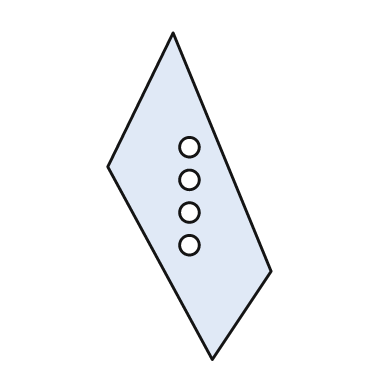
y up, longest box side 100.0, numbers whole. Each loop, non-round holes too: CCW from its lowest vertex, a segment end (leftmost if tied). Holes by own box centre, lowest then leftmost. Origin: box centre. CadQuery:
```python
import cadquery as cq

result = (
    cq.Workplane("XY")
    .moveTo(7.0, -50.0)
    .lineTo(25.0, -23.0)
    .lineTo(-5.0, 50.0)
    .lineTo(-25.0, 9.0)
    .close()
    .moveTo(0.0, -15.0)
    .circle(3.0)
    .moveTo(0.0, -5.0)
    .circle(3.0)
    .moveTo(0.0, 5.0)
    .circle(3.0)
    .moveTo(0.0, 15.0)
    .circle(3.0)
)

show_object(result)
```